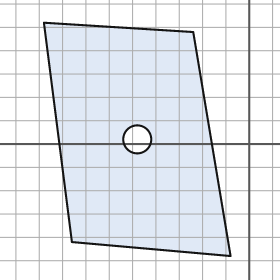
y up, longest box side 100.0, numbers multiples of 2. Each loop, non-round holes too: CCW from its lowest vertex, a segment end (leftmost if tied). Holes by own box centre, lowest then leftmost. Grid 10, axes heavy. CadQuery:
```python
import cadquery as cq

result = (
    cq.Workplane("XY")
    .moveTo(-8.0, -48.0)
    .lineTo(-24.0, 48.0)
    .lineTo(-88.0, 52.0)
    .lineTo(-76.0, -42.0)
    .close()
    .moveTo(-48.0, 2.0)
    .circle(6.0)
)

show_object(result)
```